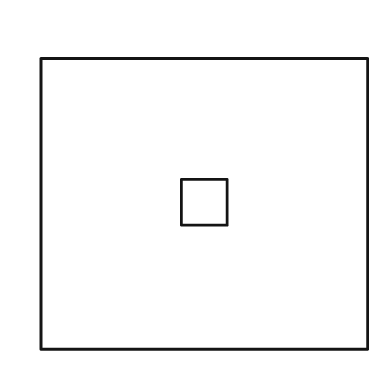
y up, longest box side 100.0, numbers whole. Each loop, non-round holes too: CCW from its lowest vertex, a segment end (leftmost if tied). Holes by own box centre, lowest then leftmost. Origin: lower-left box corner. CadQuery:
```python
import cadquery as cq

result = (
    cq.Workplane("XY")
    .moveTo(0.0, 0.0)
    .lineTo(100.0, 0.0)
    .lineTo(100.0, 89.0)
    .lineTo(0.0, 89.0)
    .close()
    .moveTo(43.0, 38.0)
    .lineTo(57.0, 38.0)
    .lineTo(57.0, 52.0)
    .lineTo(43.0, 52.0)
    .close()
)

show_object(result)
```